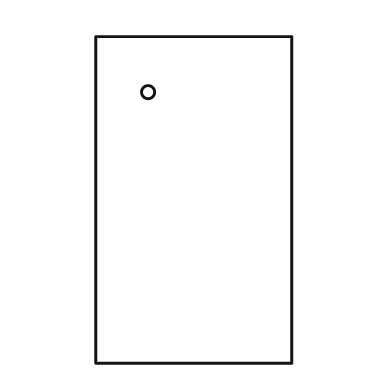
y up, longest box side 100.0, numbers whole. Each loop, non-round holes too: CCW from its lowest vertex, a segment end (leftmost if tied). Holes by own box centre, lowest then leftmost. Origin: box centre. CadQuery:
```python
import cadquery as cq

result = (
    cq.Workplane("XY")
    .moveTo(-30.0, -50.0)
    .lineTo(30.0, -50.0)
    .lineTo(30.0, 50.0)
    .lineTo(-30.0, 50.0)
    .close()
    .moveTo(-14.0, 33.0)
    .circle(2.0)
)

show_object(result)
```